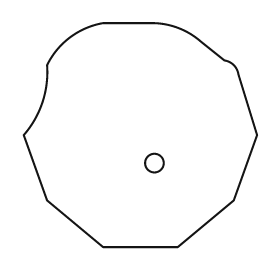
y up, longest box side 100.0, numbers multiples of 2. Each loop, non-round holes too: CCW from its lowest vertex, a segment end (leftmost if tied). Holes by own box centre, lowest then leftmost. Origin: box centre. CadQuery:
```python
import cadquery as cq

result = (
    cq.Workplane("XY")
    .moveTo(-16.0, -48.0)
    .lineTo(16.0, -48.0)
    .lineTo(40.0, -28.0)
    .lineTo(50.0, 0.0)
    .lineTo(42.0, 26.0)
    .threePointArc((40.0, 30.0), (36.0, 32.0))
    .lineTo(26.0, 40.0)
    .threePointArc((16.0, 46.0), (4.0, 48.0))
    .lineTo(-16.0, 48.0)
    .threePointArc((-30.0, 42.0), (-40.0, 30.0))
    .threePointArc((-42.0, 14.0), (-50.0, 0.0))
    .lineTo(-40.0, -28.0)
    .close()
    .moveTo(6.0, -12.0)
    .circle(4.0)
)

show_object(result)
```